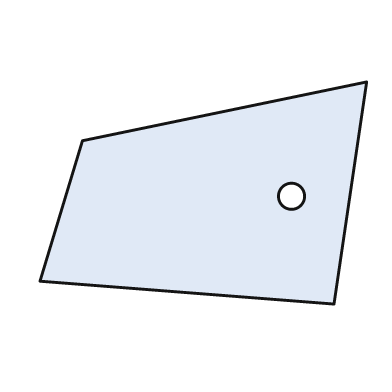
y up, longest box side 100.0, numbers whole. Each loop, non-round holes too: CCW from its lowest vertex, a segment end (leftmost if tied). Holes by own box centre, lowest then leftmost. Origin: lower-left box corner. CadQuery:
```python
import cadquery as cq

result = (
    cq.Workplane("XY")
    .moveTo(90.0, 0.0)
    .lineTo(100.0, 68.0)
    .lineTo(13.0, 50.0)
    .lineTo(0.0, 7.0)
    .close()
    .moveTo(77.0, 33.0)
    .circle(4.0)
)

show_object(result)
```